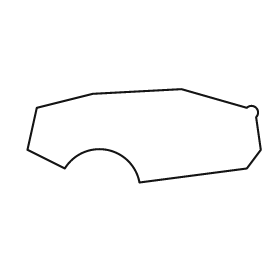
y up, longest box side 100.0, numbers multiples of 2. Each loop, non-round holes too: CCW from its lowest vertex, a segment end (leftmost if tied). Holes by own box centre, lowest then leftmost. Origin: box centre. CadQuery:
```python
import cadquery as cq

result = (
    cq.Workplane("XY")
    .moveTo(-2.0, -20.0)
    .lineTo(44.0, -14.0)
    .lineTo(50.0, -6.0)
    .lineTo(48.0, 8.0)
    .threePointArc((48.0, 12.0), (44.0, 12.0))
    .lineTo(16.0, 20.0)
    .lineTo(-22.0, 18.0)
    .lineTo(-46.0, 12.0)
    .lineTo(-50.0, -6.0)
    .lineTo(-34.0, -14.0)
    .threePointArc((-16.0, -6.0), (-2.0, -20.0))
    .close()
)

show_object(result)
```